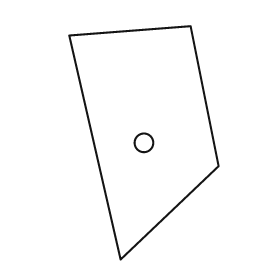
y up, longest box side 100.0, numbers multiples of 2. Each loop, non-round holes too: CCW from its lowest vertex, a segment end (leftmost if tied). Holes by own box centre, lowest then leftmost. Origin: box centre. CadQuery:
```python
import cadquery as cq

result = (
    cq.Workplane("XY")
    .moveTo(-10.0, -50.0)
    .lineTo(32.0, -10.0)
    .lineTo(20.0, 50.0)
    .lineTo(-32.0, 46.0)
    .close()
    .moveTo(0.0, 0.0)
    .circle(4.0)
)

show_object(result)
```